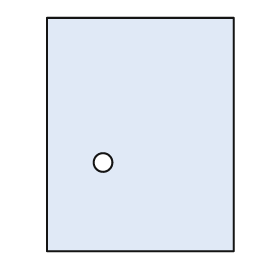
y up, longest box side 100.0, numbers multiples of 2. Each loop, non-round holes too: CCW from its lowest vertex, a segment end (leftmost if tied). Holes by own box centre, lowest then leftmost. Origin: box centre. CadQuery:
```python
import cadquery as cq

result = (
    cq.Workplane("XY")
    .moveTo(-40.0, -50.0)
    .lineTo(40.0, -50.0)
    .lineTo(40.0, 50.0)
    .lineTo(-40.0, 50.0)
    .close()
    .moveTo(-16.0, -12.0)
    .circle(4.0)
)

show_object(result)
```